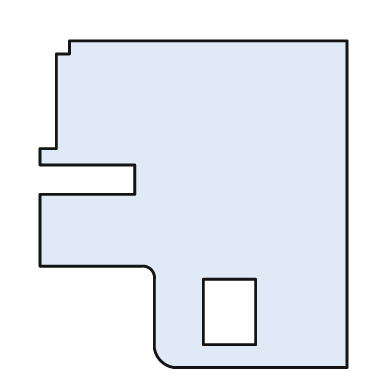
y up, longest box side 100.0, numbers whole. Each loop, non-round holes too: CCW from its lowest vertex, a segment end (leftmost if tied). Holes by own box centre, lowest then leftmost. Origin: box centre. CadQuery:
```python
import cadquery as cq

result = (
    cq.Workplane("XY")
    .moveTo(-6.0, -50.0)
    .lineTo(47.0, -50.0)
    .lineTo(47.0, 50.0)
    .lineTo(-38.0, 50.0)
    .lineTo(-38.0, 46.0)
    .lineTo(-42.0, 46.0)
    .lineTo(-42.0, 17.0)
    .lineTo(-47.0, 17.0)
    .lineTo(-47.0, 12.0)
    .lineTo(-18.0, 12.0)
    .lineTo(-18.0, 3.0)
    .lineTo(-47.0, 3.0)
    .lineTo(-47.0, -19.0)
    .lineTo(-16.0, -19.0)
    .threePointArc((-13.0, -20.0), (-12.0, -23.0))
    .lineTo(-12.0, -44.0)
    .threePointArc((-10.0, -48.0), (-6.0, -50.0))
    .close()
    .moveTo(3.0, -43.0)
    .lineTo(19.0, -43.0)
    .lineTo(19.0, -23.0)
    .lineTo(3.0, -23.0)
    .close()
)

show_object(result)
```